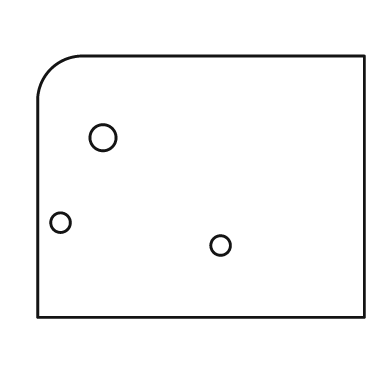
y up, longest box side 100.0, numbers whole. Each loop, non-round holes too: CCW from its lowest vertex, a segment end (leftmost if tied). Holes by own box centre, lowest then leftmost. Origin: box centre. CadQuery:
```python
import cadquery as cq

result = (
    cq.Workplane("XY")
    .moveTo(-50.0, -40.0)
    .lineTo(50.0, -40.0)
    .lineTo(50.0, 40.0)
    .lineTo(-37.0, 40.0)
    .threePointArc((-46.0, 36.0), (-50.0, 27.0))
    .close()
    .moveTo(6.0, -18.0)
    .circle(3.0)
    .moveTo(-43.0, -11.0)
    .circle(3.0)
    .moveTo(-30.0, 15.0)
    .circle(4.0)
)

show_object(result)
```